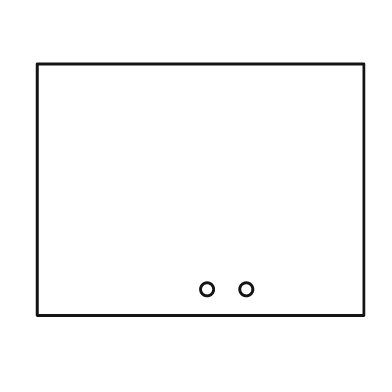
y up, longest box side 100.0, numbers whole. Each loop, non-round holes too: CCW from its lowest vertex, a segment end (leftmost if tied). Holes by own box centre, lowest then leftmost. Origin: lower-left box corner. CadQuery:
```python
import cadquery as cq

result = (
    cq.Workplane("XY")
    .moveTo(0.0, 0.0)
    .lineTo(100.0, 0.0)
    .lineTo(100.0, 77.0)
    .lineTo(0.0, 77.0)
    .close()
    .moveTo(52.0, 8.0)
    .circle(2.0)
    .moveTo(64.0, 8.0)
    .circle(2.0)
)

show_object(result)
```